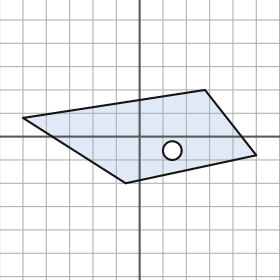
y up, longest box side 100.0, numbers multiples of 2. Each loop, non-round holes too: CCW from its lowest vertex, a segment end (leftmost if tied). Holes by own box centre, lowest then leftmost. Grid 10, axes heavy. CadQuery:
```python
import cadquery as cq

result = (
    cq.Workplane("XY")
    .moveTo(-6.0, -20.0)
    .lineTo(50.0, -8.0)
    .lineTo(28.0, 20.0)
    .lineTo(-50.0, 8.0)
    .close()
    .moveTo(14.0, -6.0)
    .circle(4.0)
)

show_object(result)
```